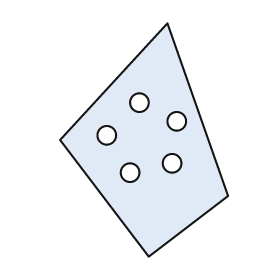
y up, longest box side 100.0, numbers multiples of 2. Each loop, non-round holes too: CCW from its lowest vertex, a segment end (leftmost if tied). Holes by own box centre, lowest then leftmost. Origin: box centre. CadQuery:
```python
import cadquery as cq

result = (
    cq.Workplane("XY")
    .moveTo(2.0, -50.0)
    .lineTo(36.0, -24.0)
    .lineTo(10.0, 50.0)
    .lineTo(-36.0, 0.0)
    .close()
    .moveTo(-6.0, -14.0)
    .circle(4.0)
    .moveTo(12.0, -10.0)
    .circle(4.0)
    .moveTo(-16.0, 2.0)
    .circle(4.0)
    .moveTo(14.0, 8.0)
    .circle(4.0)
    .moveTo(-2.0, 16.0)
    .circle(4.0)
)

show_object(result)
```